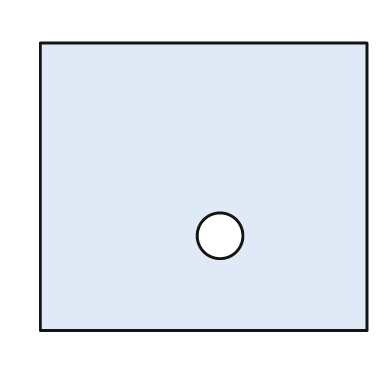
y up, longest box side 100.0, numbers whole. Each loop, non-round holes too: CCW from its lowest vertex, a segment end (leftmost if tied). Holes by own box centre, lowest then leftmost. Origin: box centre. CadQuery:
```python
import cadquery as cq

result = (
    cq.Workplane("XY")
    .moveTo(-50.0, -44.0)
    .lineTo(50.0, -44.0)
    .lineTo(50.0, 44.0)
    .lineTo(-50.0, 44.0)
    .close()
    .moveTo(5.0, -15.0)
    .circle(7.0)
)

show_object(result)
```